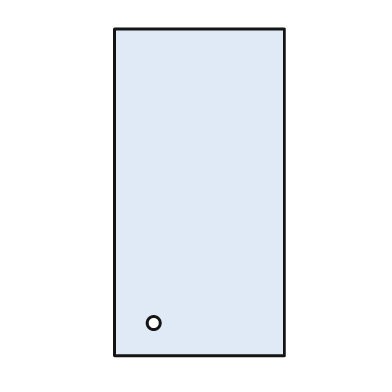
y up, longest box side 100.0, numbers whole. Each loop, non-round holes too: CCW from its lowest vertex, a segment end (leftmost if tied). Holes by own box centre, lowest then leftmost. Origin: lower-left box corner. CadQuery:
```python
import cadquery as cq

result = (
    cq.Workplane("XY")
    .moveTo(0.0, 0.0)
    .lineTo(52.0, 0.0)
    .lineTo(52.0, 100.0)
    .lineTo(0.0, 100.0)
    .close()
    .moveTo(12.0, 10.0)
    .circle(2.0)
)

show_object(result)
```